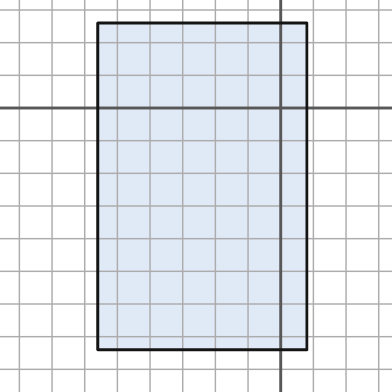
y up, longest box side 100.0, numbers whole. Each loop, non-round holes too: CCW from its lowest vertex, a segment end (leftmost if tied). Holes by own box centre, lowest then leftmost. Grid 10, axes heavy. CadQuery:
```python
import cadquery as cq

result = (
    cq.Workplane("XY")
    .moveTo(-56.0, -74.0)
    .lineTo(8.0, -74.0)
    .lineTo(8.0, 26.0)
    .lineTo(-56.0, 26.0)
    .close()
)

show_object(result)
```